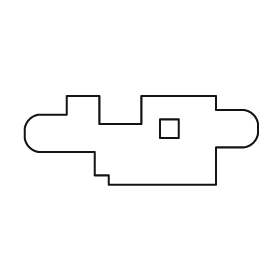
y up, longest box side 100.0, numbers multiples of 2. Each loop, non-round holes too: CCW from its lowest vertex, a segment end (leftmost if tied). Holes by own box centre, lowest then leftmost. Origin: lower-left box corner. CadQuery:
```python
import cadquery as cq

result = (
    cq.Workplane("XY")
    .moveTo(36.0, 0.0)
    .lineTo(82.0, 0.0)
    .lineTo(82.0, 16.0)
    .lineTo(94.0, 16.0)
    .threePointArc((98.0, 18.0), (100.0, 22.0))
    .lineTo(100.0, 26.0)
    .threePointArc((98.0, 30.0), (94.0, 32.0))
    .lineTo(82.0, 32.0)
    .lineTo(82.0, 38.0)
    .lineTo(50.0, 38.0)
    .lineTo(50.0, 26.0)
    .lineTo(32.0, 26.0)
    .lineTo(32.0, 38.0)
    .lineTo(18.0, 38.0)
    .lineTo(18.0, 30.0)
    .lineTo(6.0, 30.0)
    .threePointArc((2.0, 28.0), (0.0, 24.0))
    .lineTo(0.0, 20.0)
    .threePointArc((2.0, 16.0), (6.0, 14.0))
    .lineTo(30.0, 14.0)
    .lineTo(30.0, 4.0)
    .lineTo(36.0, 4.0)
    .close()
    .moveTo(58.0, 20.0)
    .lineTo(66.0, 20.0)
    .lineTo(66.0, 28.0)
    .lineTo(58.0, 28.0)
    .close()
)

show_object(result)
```